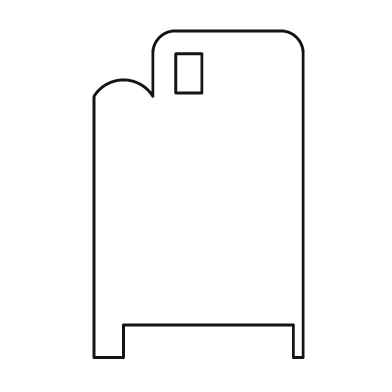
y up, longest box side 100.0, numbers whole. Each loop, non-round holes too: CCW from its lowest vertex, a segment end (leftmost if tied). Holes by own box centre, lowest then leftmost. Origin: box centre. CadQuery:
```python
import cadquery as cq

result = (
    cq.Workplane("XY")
    .moveTo(-32.0, -50.0)
    .lineTo(-23.0, -50.0)
    .lineTo(-23.0, -40.0)
    .lineTo(29.0, -40.0)
    .lineTo(29.0, -50.0)
    .lineTo(32.0, -50.0)
    .lineTo(32.0, 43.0)
    .threePointArc((30.0, 48.0), (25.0, 50.0))
    .lineTo(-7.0, 50.0)
    .threePointArc((-12.0, 48.0), (-14.0, 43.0))
    .lineTo(-14.0, 30.0)
    .threePointArc((-23.0, 35.0), (-32.0, 30.0))
    .close()
    .moveTo(-7.0, 31.0)
    .lineTo(1.0, 31.0)
    .lineTo(1.0, 43.0)
    .lineTo(-7.0, 43.0)
    .close()
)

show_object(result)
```